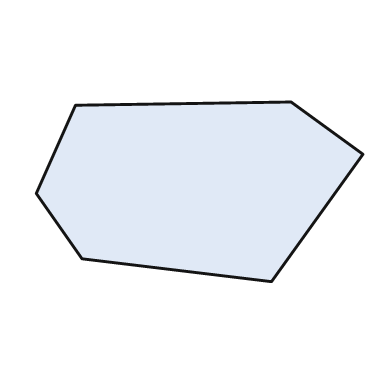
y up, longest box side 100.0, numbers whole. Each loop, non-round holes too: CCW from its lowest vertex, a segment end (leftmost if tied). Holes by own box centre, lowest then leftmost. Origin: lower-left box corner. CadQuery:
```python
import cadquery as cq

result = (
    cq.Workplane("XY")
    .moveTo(72.0, 0.0)
    .lineTo(100.0, 39.0)
    .lineTo(78.0, 55.0)
    .lineTo(12.0, 54.0)
    .lineTo(0.0, 27.0)
    .lineTo(14.0, 7.0)
    .close()
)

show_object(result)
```